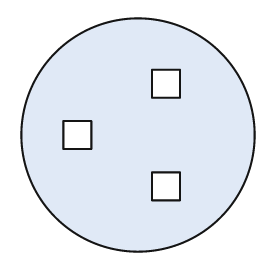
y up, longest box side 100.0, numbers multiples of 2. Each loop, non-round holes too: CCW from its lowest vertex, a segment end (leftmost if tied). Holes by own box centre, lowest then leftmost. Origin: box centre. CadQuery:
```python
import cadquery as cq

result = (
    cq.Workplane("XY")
    .moveTo(0.0, 0.0)
    .circle(50.0)
    .moveTo(6.0, -28.0)
    .lineTo(18.0, -28.0)
    .lineTo(18.0, -16.0)
    .lineTo(6.0, -16.0)
    .close()
    .moveTo(-32.0, -6.0)
    .lineTo(-20.0, -6.0)
    .lineTo(-20.0, 6.0)
    .lineTo(-32.0, 6.0)
    .close()
    .moveTo(6.0, 16.0)
    .lineTo(18.0, 16.0)
    .lineTo(18.0, 28.0)
    .lineTo(6.0, 28.0)
    .close()
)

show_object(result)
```